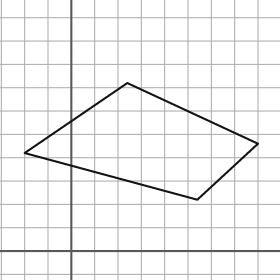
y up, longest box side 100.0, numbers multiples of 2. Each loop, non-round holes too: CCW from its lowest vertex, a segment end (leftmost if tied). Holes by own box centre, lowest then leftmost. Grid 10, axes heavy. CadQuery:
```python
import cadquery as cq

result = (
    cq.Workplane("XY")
    .moveTo(54.0, 22.0)
    .lineTo(80.0, 46.0)
    .lineTo(24.0, 72.0)
    .lineTo(-20.0, 42.0)
    .close()
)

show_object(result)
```